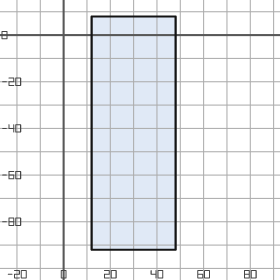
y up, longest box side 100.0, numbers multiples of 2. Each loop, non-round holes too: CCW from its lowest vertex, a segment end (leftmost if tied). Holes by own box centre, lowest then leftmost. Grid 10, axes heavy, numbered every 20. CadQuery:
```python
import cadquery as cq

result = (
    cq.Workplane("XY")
    .moveTo(12.0, -92.0)
    .lineTo(48.0, -92.0)
    .lineTo(48.0, 8.0)
    .lineTo(12.0, 8.0)
    .close()
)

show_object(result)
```